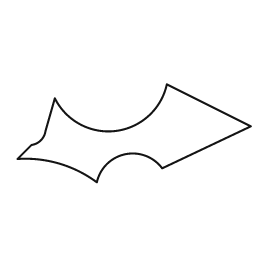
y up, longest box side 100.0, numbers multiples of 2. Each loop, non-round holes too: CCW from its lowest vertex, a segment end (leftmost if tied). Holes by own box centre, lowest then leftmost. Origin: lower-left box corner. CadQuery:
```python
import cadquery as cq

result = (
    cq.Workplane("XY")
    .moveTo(34.0, 0.0)
    .threePointArc((46.0, 12.0), (62.0, 6.0))
    .lineTo(100.0, 24.0)
    .lineTo(64.0, 42.0)
    .threePointArc((42.0, 22.0), (16.0, 36.0))
    .lineTo(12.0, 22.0)
    .threePointArc((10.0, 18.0), (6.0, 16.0))
    .lineTo(0.0, 10.0)
    .threePointArc((18.0, 8.0), (34.0, 0.0))
    .close()
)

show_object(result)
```